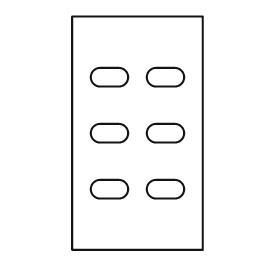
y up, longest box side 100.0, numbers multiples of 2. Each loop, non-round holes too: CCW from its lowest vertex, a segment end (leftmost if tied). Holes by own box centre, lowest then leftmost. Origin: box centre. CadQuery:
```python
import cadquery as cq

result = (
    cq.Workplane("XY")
    .moveTo(-28.0, -50.0)
    .lineTo(28.0, -50.0)
    .lineTo(28.0, 50.0)
    .lineTo(-28.0, 50.0)
    .close()
    .moveTo(-16.0, -28.0)
    .lineTo(-8.0, -28.0)
    .threePointArc((-4.0, -24.0), (-8.0, -20.0))
    .lineTo(-16.0, -20.0)
    .threePointArc((-20.0, -24.0), (-16.0, -28.0))
    .close()
    .moveTo(8.0, -28.0)
    .lineTo(16.0, -28.0)
    .threePointArc((20.0, -24.0), (16.0, -20.0))
    .lineTo(8.0, -20.0)
    .threePointArc((4.0, -24.0), (8.0, -28.0))
    .close()
    .moveTo(-16.0, -4.0)
    .lineTo(-8.0, -4.0)
    .threePointArc((-4.0, 0.0), (-8.0, 4.0))
    .lineTo(-16.0, 4.0)
    .threePointArc((-20.0, 0.0), (-16.0, -4.0))
    .close()
    .moveTo(8.0, -4.0)
    .lineTo(16.0, -4.0)
    .threePointArc((20.0, 0.0), (16.0, 4.0))
    .lineTo(8.0, 4.0)
    .threePointArc((4.0, 0.0), (8.0, -4.0))
    .close()
    .moveTo(-16.0, 20.0)
    .lineTo(-8.0, 20.0)
    .threePointArc((-4.0, 24.0), (-8.0, 28.0))
    .lineTo(-16.0, 28.0)
    .threePointArc((-20.0, 24.0), (-16.0, 20.0))
    .close()
    .moveTo(8.0, 20.0)
    .lineTo(16.0, 20.0)
    .threePointArc((20.0, 24.0), (16.0, 28.0))
    .lineTo(8.0, 28.0)
    .threePointArc((4.0, 24.0), (8.0, 20.0))
    .close()
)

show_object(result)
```